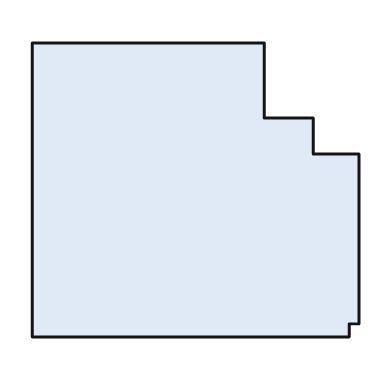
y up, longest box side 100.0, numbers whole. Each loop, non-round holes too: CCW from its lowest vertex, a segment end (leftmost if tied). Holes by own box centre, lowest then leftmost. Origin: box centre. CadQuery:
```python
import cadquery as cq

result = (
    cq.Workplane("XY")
    .moveTo(-50.0, -45.0)
    .lineTo(47.0, -45.0)
    .lineTo(47.0, -41.0)
    .lineTo(50.0, -41.0)
    .lineTo(50.0, 11.0)
    .lineTo(36.0, 11.0)
    .lineTo(36.0, 22.0)
    .lineTo(21.0, 22.0)
    .lineTo(21.0, 45.0)
    .lineTo(-50.0, 45.0)
    .close()
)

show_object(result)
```